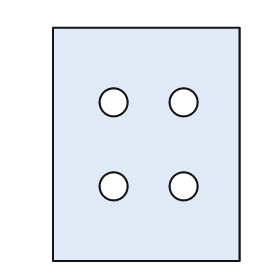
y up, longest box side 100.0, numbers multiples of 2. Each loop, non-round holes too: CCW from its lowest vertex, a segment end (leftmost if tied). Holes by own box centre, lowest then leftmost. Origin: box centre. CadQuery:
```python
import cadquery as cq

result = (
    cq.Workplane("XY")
    .moveTo(-40.0, -50.0)
    .lineTo(40.0, -50.0)
    .lineTo(40.0, 50.0)
    .lineTo(-40.0, 50.0)
    .close()
    .moveTo(-14.0, -18.0)
    .circle(6.0)
    .moveTo(16.0, -18.0)
    .circle(6.0)
    .moveTo(-14.0, 18.0)
    .circle(6.0)
    .moveTo(16.0, 18.0)
    .circle(6.0)
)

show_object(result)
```